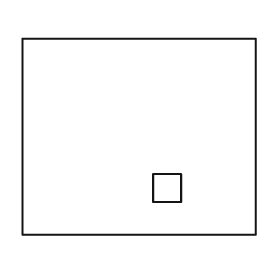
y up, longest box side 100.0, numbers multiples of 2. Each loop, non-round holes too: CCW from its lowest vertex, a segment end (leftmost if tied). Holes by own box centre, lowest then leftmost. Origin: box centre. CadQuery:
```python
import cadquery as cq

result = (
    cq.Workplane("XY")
    .moveTo(-50.0, -42.0)
    .lineTo(50.0, -42.0)
    .lineTo(50.0, 42.0)
    .lineTo(-50.0, 42.0)
    .close()
    .moveTo(6.0, -28.0)
    .lineTo(18.0, -28.0)
    .lineTo(18.0, -16.0)
    .lineTo(6.0, -16.0)
    .close()
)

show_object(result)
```